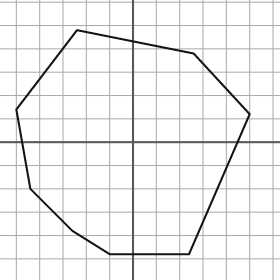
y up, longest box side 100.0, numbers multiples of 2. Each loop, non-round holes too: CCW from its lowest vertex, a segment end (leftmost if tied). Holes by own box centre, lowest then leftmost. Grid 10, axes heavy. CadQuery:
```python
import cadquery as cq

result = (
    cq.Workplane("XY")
    .moveTo(-10.0, -48.0)
    .lineTo(24.0, -48.0)
    .lineTo(50.0, 12.0)
    .lineTo(26.0, 38.0)
    .lineTo(-24.0, 48.0)
    .lineTo(-50.0, 14.0)
    .lineTo(-44.0, -20.0)
    .lineTo(-26.0, -38.0)
    .close()
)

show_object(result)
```